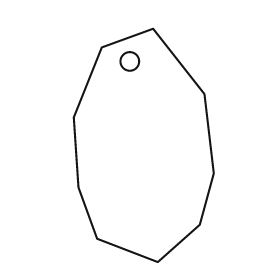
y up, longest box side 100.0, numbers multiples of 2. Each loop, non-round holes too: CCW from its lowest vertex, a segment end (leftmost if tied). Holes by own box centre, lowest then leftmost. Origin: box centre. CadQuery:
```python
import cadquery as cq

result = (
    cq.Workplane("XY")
    .moveTo(6.0, -50.0)
    .lineTo(24.0, -34.0)
    .lineTo(30.0, -12.0)
    .lineTo(26.0, 22.0)
    .lineTo(4.0, 50.0)
    .lineTo(-18.0, 42.0)
    .lineTo(-30.0, 12.0)
    .lineTo(-28.0, -18.0)
    .lineTo(-20.0, -40.0)
    .close()
    .moveTo(-6.0, 36.0)
    .circle(4.0)
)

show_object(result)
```